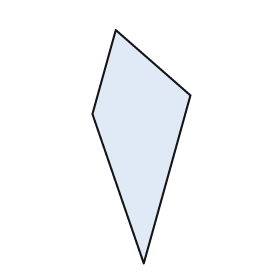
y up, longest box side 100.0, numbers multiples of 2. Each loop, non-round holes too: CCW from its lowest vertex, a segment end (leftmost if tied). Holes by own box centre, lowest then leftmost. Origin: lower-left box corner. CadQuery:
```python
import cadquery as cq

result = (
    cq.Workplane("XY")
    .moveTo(22.0, 0.0)
    .lineTo(42.0, 72.0)
    .lineTo(10.0, 100.0)
    .lineTo(0.0, 64.0)
    .close()
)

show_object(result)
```